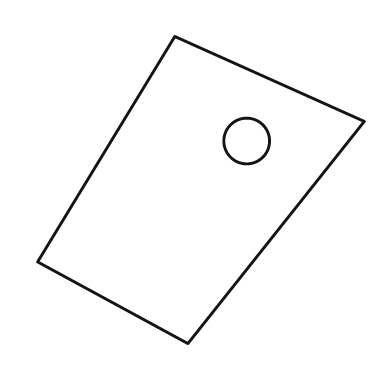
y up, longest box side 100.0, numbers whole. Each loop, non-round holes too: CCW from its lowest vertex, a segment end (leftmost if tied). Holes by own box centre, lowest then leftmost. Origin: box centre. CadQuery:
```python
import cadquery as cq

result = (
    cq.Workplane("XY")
    .moveTo(-4.0, -47.0)
    .lineTo(50.0, 21.0)
    .lineTo(-8.0, 47.0)
    .lineTo(-50.0, -22.0)
    .close()
    .moveTo(14.0, 15.0)
    .circle(7.0)
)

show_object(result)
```